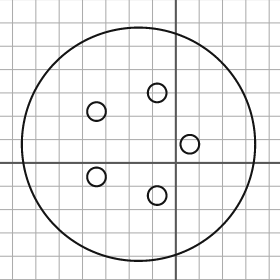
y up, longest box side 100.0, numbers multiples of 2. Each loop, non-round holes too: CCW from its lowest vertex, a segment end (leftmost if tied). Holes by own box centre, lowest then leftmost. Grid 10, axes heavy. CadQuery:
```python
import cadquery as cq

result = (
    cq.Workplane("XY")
    .moveTo(-16.0, 8.0)
    .circle(50.0)
    .moveTo(-8.0, -14.0)
    .circle(4.0)
    .moveTo(-34.0, -6.0)
    .circle(4.0)
    .moveTo(6.0, 8.0)
    .circle(4.0)
    .moveTo(-34.0, 22.0)
    .circle(4.0)
    .moveTo(-8.0, 30.0)
    .circle(4.0)
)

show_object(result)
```